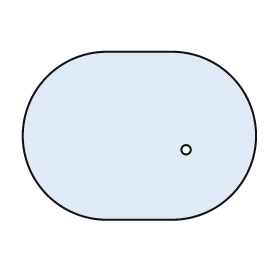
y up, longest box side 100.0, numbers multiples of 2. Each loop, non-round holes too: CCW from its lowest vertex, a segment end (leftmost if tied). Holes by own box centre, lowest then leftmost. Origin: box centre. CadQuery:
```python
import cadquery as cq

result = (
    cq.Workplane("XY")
    .moveTo(-14.0, -36.0)
    .lineTo(14.0, -36.0)
    .threePointArc((50.0, 0.0), (14.0, 36.0))
    .lineTo(-14.0, 36.0)
    .threePointArc((-50.0, 0.0), (-14.0, -36.0))
    .close()
    .moveTo(20.0, -6.0)
    .circle(2.0)
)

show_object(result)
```